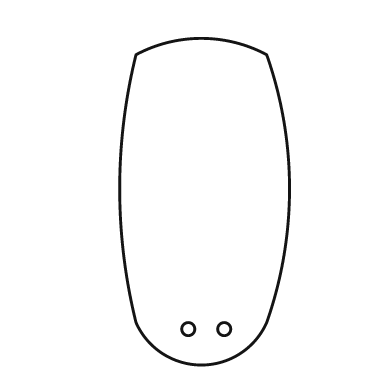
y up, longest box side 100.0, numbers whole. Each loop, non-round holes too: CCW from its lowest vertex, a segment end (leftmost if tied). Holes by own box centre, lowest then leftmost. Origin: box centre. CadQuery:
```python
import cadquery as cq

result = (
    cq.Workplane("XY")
    .moveTo(-21.0, -37.0)
    .threePointArc((-1.0, -50.0), (19.0, -37.0))
    .threePointArc((26.0, 4.0), (19.0, 45.0))
    .threePointArc((-1.0, 50.0), (-21.0, 45.0))
    .threePointArc((-26.0, 4.0), (-21.0, -37.0))
    .close()
    .moveTo(-5.0, -39.0)
    .circle(2.0)
    .moveTo(6.0, -39.0)
    .circle(2.0)
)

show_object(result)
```